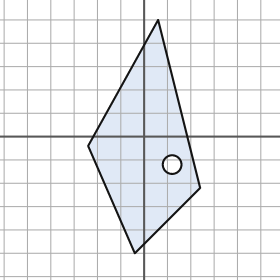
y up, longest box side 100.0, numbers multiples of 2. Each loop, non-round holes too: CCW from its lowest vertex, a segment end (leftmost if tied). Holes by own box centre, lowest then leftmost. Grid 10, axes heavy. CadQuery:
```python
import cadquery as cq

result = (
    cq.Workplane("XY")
    .moveTo(-4.0, -50.0)
    .lineTo(24.0, -22.0)
    .lineTo(6.0, 50.0)
    .lineTo(-24.0, -4.0)
    .close()
    .moveTo(12.0, -12.0)
    .circle(4.0)
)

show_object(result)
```